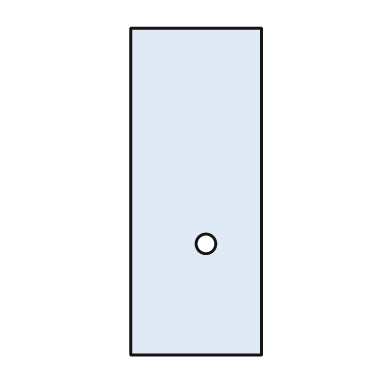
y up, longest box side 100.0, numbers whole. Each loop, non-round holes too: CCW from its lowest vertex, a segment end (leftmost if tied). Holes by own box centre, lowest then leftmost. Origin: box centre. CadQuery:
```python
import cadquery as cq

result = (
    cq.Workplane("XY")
    .moveTo(-20.0, -50.0)
    .lineTo(20.0, -50.0)
    .lineTo(20.0, 50.0)
    .lineTo(-20.0, 50.0)
    .close()
    .moveTo(3.0, -16.0)
    .circle(3.0)
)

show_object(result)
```